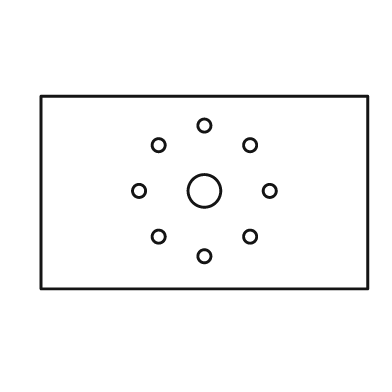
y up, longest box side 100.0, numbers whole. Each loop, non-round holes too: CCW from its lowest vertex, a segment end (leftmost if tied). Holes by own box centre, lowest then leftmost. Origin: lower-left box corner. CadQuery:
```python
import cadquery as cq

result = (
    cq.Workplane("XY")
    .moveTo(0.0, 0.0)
    .lineTo(100.0, 0.0)
    .lineTo(100.0, 59.0)
    .lineTo(0.0, 59.0)
    .close()
    .moveTo(50.0, 10.0)
    .circle(2.0)
    .moveTo(36.0, 16.0)
    .circle(2.0)
    .moveTo(64.0, 16.0)
    .circle(2.0)
    .moveTo(30.0, 30.0)
    .circle(2.0)
    .moveTo(50.0, 30.0)
    .circle(5.0)
    .moveTo(70.0, 30.0)
    .circle(2.0)
    .moveTo(36.0, 44.0)
    .circle(2.0)
    .moveTo(64.0, 44.0)
    .circle(2.0)
    .moveTo(50.0, 50.0)
    .circle(2.0)
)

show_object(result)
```